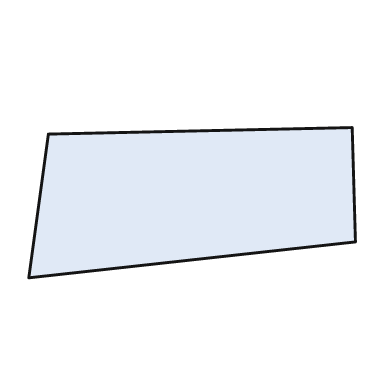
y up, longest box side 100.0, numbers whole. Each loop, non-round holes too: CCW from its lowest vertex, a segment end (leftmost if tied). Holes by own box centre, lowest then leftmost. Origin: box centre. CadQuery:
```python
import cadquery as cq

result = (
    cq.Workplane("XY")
    .moveTo(-50.0, -23.0)
    .lineTo(50.0, -12.0)
    .lineTo(49.0, 23.0)
    .lineTo(-44.0, 21.0)
    .close()
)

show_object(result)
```